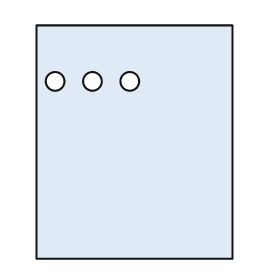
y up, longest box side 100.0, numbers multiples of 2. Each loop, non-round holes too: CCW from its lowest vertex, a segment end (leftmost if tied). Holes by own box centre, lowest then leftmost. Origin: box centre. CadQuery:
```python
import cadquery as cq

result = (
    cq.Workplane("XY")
    .moveTo(-42.0, -50.0)
    .lineTo(42.0, -50.0)
    .lineTo(42.0, 50.0)
    .lineTo(-42.0, 50.0)
    .close()
    .moveTo(-34.0, 26.0)
    .circle(4.0)
    .moveTo(-18.0, 26.0)
    .circle(4.0)
    .moveTo(-2.0, 26.0)
    .circle(4.0)
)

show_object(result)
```